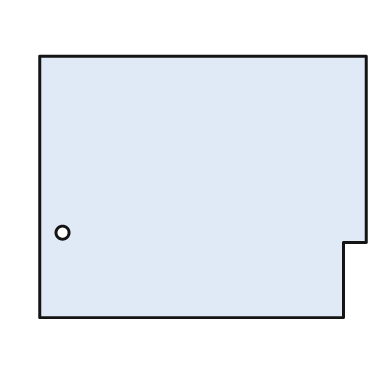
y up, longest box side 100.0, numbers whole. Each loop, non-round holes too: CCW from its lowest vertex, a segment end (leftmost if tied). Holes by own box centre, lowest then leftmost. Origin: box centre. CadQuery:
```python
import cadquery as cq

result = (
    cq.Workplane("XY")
    .moveTo(-50.0, -40.0)
    .lineTo(43.0, -40.0)
    .lineTo(43.0, -17.0)
    .lineTo(50.0, -17.0)
    .lineTo(50.0, 40.0)
    .lineTo(-50.0, 40.0)
    .close()
    .moveTo(-43.0, -14.0)
    .circle(2.0)
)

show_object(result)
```